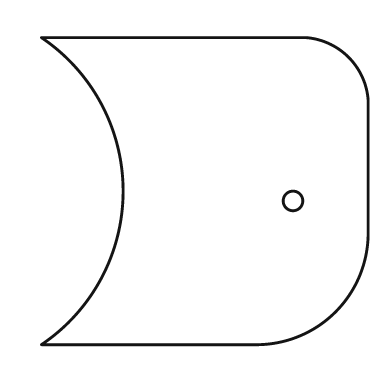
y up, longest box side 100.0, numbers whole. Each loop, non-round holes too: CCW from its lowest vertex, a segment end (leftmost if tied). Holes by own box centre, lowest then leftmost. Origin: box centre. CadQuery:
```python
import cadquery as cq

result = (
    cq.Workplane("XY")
    .moveTo(-50.0, -47.0)
    .lineTo(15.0, -47.0)
    .threePointArc((40.0, -37.0), (50.0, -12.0))
    .lineTo(50.0, 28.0)
    .threePointArc((44.0, 41.0), (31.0, 47.0))
    .lineTo(-50.0, 47.0)
    .threePointArc((-25.0, 0.0), (-50.0, -47.0))
    .close()
    .moveTo(27.0, -3.0)
    .circle(3.0)
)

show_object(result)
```